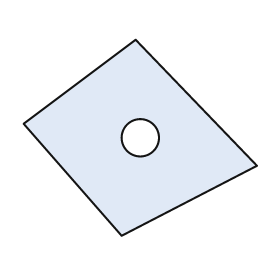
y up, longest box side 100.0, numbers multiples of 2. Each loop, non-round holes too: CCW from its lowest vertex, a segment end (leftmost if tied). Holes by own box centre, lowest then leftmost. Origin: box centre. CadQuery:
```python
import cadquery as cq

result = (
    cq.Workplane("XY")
    .moveTo(-8.0, -42.0)
    .lineTo(50.0, -12.0)
    .lineTo(-2.0, 42.0)
    .lineTo(-50.0, 6.0)
    .close()
    .moveTo(0.0, 0.0)
    .circle(8.0)
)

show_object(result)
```